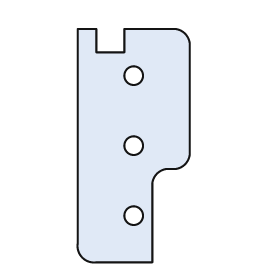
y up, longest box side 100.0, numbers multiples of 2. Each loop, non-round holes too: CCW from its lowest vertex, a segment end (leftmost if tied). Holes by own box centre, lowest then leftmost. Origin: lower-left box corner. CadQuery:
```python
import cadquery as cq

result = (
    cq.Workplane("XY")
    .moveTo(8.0, 0.0)
    .lineTo(32.0, 0.0)
    .lineTo(32.0, 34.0)
    .threePointArc((34.0, 38.0), (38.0, 40.0))
    .lineTo(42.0, 40.0)
    .threePointArc((46.0, 42.0), (48.0, 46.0))
    .lineTo(48.0, 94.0)
    .threePointArc((46.0, 98.0), (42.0, 100.0))
    .lineTo(20.0, 100.0)
    .lineTo(20.0, 90.0)
    .lineTo(8.0, 90.0)
    .lineTo(8.0, 100.0)
    .lineTo(0.0, 100.0)
    .lineTo(0.0, 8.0)
    .threePointArc((2.0, 2.0), (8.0, 0.0))
    .close()
    .moveTo(24.0, 20.0)
    .circle(4.0)
    .moveTo(24.0, 50.0)
    .circle(4.0)
    .moveTo(24.0, 80.0)
    .circle(4.0)
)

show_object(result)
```